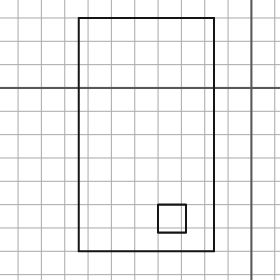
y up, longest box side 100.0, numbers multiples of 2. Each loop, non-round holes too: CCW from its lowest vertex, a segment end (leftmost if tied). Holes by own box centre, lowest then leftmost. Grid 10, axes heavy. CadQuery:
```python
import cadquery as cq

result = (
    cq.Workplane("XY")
    .moveTo(-74.0, -70.0)
    .lineTo(-16.0, -70.0)
    .lineTo(-16.0, 30.0)
    .lineTo(-74.0, 30.0)
    .close()
    .moveTo(-40.0, -62.0)
    .lineTo(-28.0, -62.0)
    .lineTo(-28.0, -50.0)
    .lineTo(-40.0, -50.0)
    .close()
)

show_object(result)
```